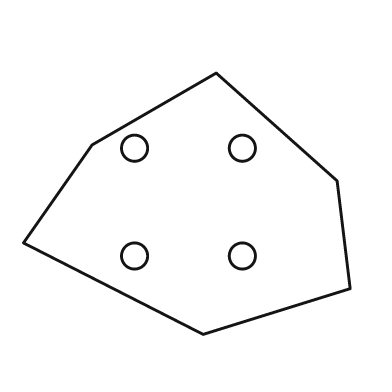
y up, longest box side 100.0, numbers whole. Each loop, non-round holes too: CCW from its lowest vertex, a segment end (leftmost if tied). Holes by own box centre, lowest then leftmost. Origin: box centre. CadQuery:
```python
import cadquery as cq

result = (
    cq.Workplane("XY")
    .moveTo(5.0, -40.0)
    .lineTo(50.0, -26.0)
    .lineTo(46.0, 7.0)
    .lineTo(9.0, 40.0)
    .lineTo(-29.0, 18.0)
    .lineTo(-50.0, -12.0)
    .close()
    .moveTo(-16.0, -16.0)
    .circle(4.0)
    .moveTo(17.0, -16.0)
    .circle(4.0)
    .moveTo(-16.0, 17.0)
    .circle(4.0)
    .moveTo(17.0, 17.0)
    .circle(4.0)
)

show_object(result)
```